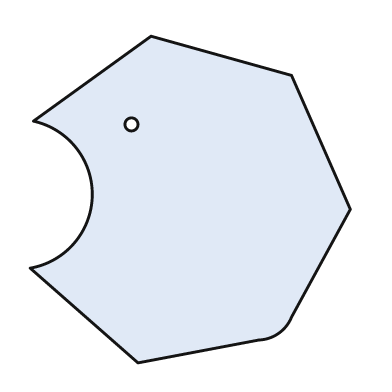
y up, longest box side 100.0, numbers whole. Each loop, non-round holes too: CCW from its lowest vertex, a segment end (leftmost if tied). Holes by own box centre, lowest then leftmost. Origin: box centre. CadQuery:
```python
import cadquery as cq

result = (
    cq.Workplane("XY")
    .moveTo(-16.0, -50.0)
    .lineTo(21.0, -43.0)
    .threePointArc((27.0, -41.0), (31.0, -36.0))
    .lineTo(49.0, -3.0)
    .lineTo(31.0, 38.0)
    .lineTo(-12.0, 50.0)
    .lineTo(-48.0, 24.0)
    .threePointArc((-30.0, 1.0), (-49.0, -21.0))
    .close()
    .moveTo(-18.0, 23.0)
    .circle(2.0)
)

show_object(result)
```